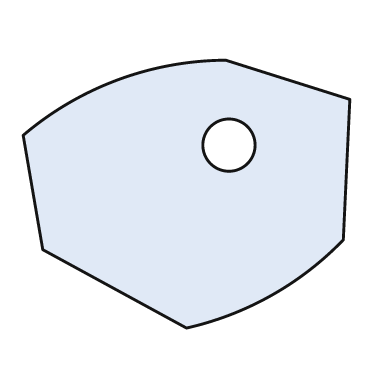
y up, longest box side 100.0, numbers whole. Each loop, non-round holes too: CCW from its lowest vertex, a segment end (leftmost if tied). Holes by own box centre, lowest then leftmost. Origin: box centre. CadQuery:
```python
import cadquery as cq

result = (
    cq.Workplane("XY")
    .moveTo(0.0, -41.0)
    .threePointArc((26.0, -31.0), (48.0, -14.0))
    .lineTo(50.0, 29.0)
    .lineTo(12.0, 41.0)
    .threePointArc((-21.0, 35.0), (-50.0, 18.0))
    .lineTo(-44.0, -17.0)
    .close()
    .moveTo(13.0, 15.0)
    .circle(8.0)
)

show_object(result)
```